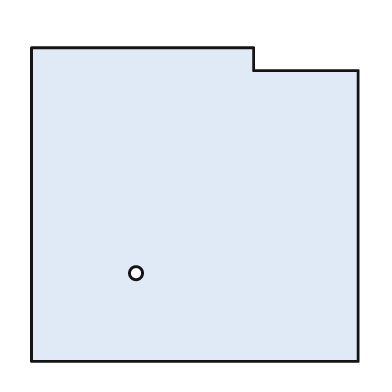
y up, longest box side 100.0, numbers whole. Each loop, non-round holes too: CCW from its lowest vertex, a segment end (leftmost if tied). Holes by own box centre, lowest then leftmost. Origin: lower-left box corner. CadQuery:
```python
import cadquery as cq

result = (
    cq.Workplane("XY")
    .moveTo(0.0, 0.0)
    .lineTo(100.0, 0.0)
    .lineTo(100.0, 89.0)
    .lineTo(68.0, 89.0)
    .lineTo(68.0, 96.0)
    .lineTo(0.0, 96.0)
    .close()
    .moveTo(32.0, 27.0)
    .circle(2.0)
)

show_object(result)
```